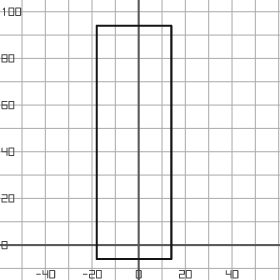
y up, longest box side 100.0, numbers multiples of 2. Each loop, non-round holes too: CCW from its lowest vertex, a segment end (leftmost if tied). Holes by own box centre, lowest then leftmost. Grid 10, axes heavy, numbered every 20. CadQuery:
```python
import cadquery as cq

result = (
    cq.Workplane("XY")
    .moveTo(-18.0, -6.0)
    .lineTo(14.0, -6.0)
    .lineTo(14.0, 94.0)
    .lineTo(-18.0, 94.0)
    .close()
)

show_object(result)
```